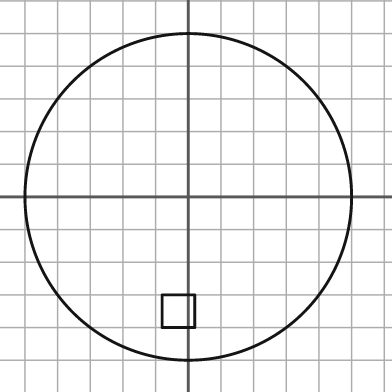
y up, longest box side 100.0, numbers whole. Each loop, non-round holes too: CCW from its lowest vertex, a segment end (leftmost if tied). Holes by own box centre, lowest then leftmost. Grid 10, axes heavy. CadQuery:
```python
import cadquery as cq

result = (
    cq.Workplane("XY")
    .moveTo(0.0, 0.0)
    .circle(50.0)
    .moveTo(-8.0, -40.0)
    .lineTo(2.0, -40.0)
    .lineTo(2.0, -30.0)
    .lineTo(-8.0, -30.0)
    .close()
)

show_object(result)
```